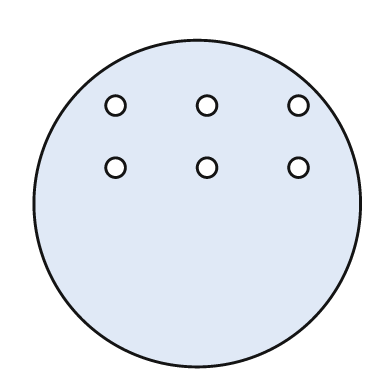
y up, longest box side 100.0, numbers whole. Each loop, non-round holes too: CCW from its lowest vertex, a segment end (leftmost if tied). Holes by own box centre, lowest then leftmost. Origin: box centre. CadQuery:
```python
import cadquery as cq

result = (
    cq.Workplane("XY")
    .moveTo(0.0, 0.0)
    .circle(50.0)
    .moveTo(-25.0, 11.0)
    .circle(3.0)
    .moveTo(3.0, 11.0)
    .circle(3.0)
    .moveTo(31.0, 11.0)
    .circle(3.0)
    .moveTo(-25.0, 30.0)
    .circle(3.0)
    .moveTo(3.0, 30.0)
    .circle(3.0)
    .moveTo(31.0, 30.0)
    .circle(3.0)
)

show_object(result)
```